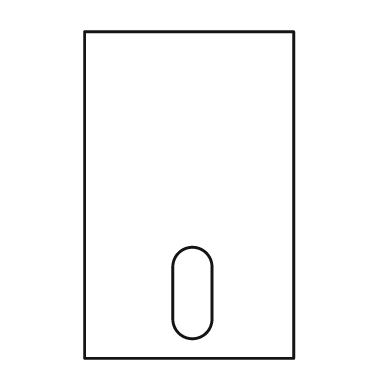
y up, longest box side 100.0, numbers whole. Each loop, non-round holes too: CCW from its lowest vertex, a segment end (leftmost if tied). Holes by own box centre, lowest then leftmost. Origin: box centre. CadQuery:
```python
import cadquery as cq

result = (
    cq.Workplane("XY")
    .moveTo(-32.0, -50.0)
    .lineTo(32.0, -50.0)
    .lineTo(32.0, 50.0)
    .lineTo(-32.0, 50.0)
    .close()
    .moveTo(-5.0, -38.0)
    .threePointArc((1.0, -44.0), (7.0, -38.0))
    .lineTo(7.0, -22.0)
    .threePointArc((1.0, -16.0), (-5.0, -22.0))
    .close()
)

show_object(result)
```